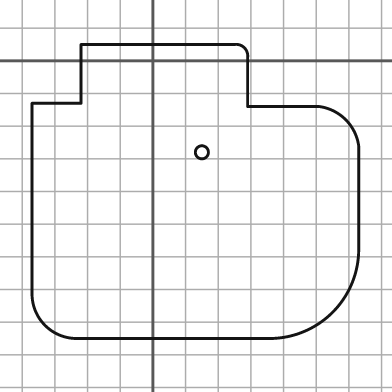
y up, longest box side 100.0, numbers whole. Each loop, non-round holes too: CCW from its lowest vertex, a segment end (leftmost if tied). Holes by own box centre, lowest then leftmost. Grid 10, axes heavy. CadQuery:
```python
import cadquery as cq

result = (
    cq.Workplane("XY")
    .moveTo(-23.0, -85.0)
    .lineTo(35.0, -85.0)
    .threePointArc((55.0, -77.0), (63.0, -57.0))
    .lineTo(63.0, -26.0)
    .threePointArc((59.0, -18.0), (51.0, -14.0))
    .lineTo(29.0, -14.0)
    .lineTo(29.0, 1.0)
    .threePointArc((28.0, 4.0), (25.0, 5.0))
    .lineTo(-22.0, 5.0)
    .lineTo(-22.0, -13.0)
    .lineTo(-37.0, -13.0)
    .lineTo(-37.0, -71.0)
    .threePointArc((-33.0, -81.0), (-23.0, -85.0))
    .close()
    .moveTo(15.0, -28.0)
    .circle(2.0)
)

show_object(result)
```